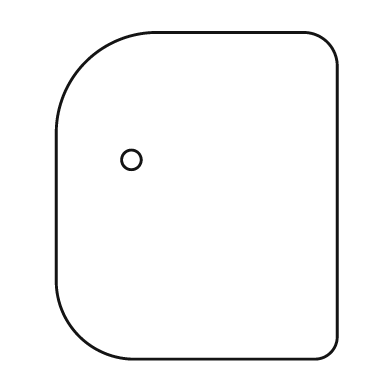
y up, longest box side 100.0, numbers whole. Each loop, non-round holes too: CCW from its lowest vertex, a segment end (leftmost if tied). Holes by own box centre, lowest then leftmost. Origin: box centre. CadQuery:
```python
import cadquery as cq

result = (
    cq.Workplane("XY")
    .moveTo(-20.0, -50.0)
    .lineTo(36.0, -50.0)
    .threePointArc((41.0, -48.0), (43.0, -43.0))
    .lineTo(43.0, 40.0)
    .threePointArc((40.0, 47.0), (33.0, 50.0))
    .lineTo(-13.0, 50.0)
    .threePointArc((-34.0, 41.0), (-43.0, 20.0))
    .lineTo(-43.0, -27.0)
    .threePointArc((-36.0, -43.0), (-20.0, -50.0))
    .close()
    .moveTo(-20.0, 11.0)
    .circle(3.0)
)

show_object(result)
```